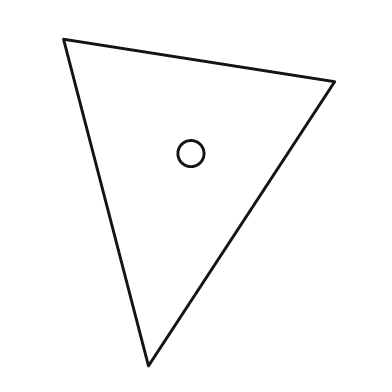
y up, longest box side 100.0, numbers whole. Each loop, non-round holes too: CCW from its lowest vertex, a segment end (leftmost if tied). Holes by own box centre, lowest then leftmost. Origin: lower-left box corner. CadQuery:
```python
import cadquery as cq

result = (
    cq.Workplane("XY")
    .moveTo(26.0, 0.0)
    .lineTo(83.0, 87.0)
    .lineTo(0.0, 100.0)
    .close()
    .moveTo(39.0, 65.0)
    .circle(4.0)
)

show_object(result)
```